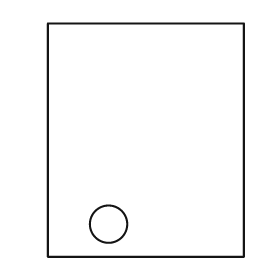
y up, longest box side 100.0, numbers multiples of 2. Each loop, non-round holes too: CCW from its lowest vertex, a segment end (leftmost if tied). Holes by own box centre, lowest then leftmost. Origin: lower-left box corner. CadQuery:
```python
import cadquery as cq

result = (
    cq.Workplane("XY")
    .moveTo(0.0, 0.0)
    .lineTo(84.0, 0.0)
    .lineTo(84.0, 100.0)
    .lineTo(0.0, 100.0)
    .close()
    .moveTo(26.0, 14.0)
    .circle(8.0)
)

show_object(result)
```